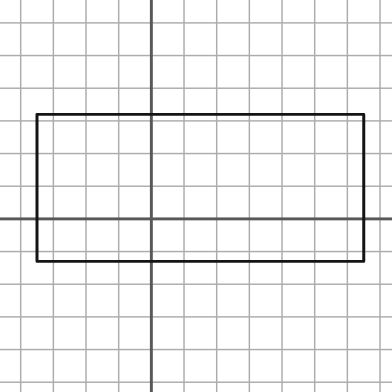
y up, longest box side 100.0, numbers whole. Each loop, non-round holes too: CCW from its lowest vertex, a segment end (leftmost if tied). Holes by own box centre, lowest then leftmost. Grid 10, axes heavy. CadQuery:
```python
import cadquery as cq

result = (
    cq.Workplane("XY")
    .moveTo(-35.0, -13.0)
    .lineTo(65.0, -13.0)
    .lineTo(65.0, 32.0)
    .lineTo(-35.0, 32.0)
    .close()
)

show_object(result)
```